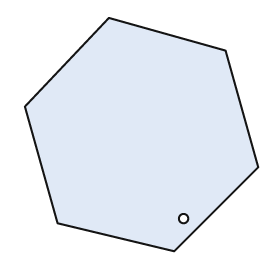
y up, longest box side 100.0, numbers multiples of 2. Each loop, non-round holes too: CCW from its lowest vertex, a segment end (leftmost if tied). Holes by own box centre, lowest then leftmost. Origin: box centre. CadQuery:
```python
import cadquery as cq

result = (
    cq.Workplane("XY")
    .moveTo(14.0, -50.0)
    .lineTo(50.0, -14.0)
    .lineTo(36.0, 36.0)
    .lineTo(-14.0, 50.0)
    .lineTo(-50.0, 12.0)
    .lineTo(-36.0, -38.0)
    .close()
    .moveTo(18.0, -36.0)
    .circle(2.0)
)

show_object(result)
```